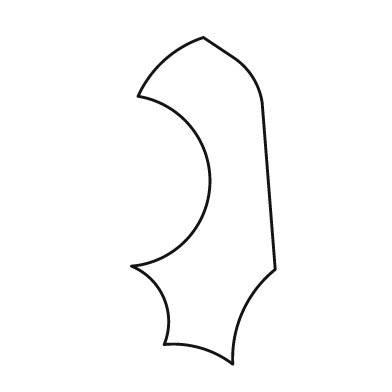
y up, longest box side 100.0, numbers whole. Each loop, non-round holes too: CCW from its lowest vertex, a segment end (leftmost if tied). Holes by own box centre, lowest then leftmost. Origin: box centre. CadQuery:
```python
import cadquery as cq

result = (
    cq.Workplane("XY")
    .moveTo(9.0, -50.0)
    .threePointArc((12.0, -34.0), (22.0, -21.0))
    .lineTo(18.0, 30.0)
    .threePointArc((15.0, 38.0), (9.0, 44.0))
    .lineTo(0.0, 50.0)
    .threePointArc((-12.0, 43.0), (-20.0, 32.0))
    .threePointArc((2.0, 5.0), (-22.0, -20.0))
    .threePointArc((-12.0, -30.0), (-12.0, -44.0))
    .threePointArc((-1.0, -45.0), (9.0, -50.0))
    .close()
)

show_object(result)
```